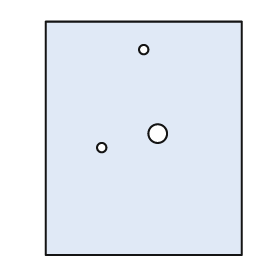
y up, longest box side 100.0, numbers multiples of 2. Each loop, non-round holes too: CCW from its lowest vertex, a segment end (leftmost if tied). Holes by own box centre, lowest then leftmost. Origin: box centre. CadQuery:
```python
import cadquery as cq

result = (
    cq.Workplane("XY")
    .moveTo(-42.0, -50.0)
    .lineTo(42.0, -50.0)
    .lineTo(42.0, 50.0)
    .lineTo(-42.0, 50.0)
    .close()
    .moveTo(-18.0, -4.0)
    .circle(2.0)
    .moveTo(6.0, 2.0)
    .circle(4.0)
    .moveTo(0.0, 38.0)
    .circle(2.0)
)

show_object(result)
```